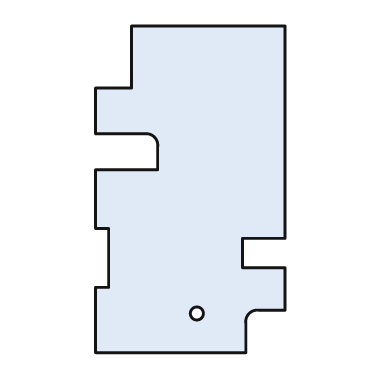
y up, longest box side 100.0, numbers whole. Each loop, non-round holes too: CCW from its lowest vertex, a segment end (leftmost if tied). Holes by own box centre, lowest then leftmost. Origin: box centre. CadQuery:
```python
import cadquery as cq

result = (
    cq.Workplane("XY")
    .moveTo(-29.0, -50.0)
    .lineTo(17.0, -50.0)
    .lineTo(17.0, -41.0)
    .threePointArc((18.0, -38.0), (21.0, -37.0))
    .lineTo(29.0, -37.0)
    .lineTo(29.0, -24.0)
    .lineTo(16.0, -24.0)
    .lineTo(16.0, -15.0)
    .lineTo(29.0, -15.0)
    .lineTo(29.0, 50.0)
    .lineTo(-18.0, 50.0)
    .lineTo(-18.0, 31.0)
    .lineTo(-29.0, 31.0)
    .lineTo(-29.0, 17.0)
    .lineTo(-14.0, 17.0)
    .threePointArc((-11.0, 16.0), (-10.0, 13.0))
    .lineTo(-10.0, 6.0)
    .lineTo(-29.0, 6.0)
    .lineTo(-29.0, -12.0)
    .lineTo(-25.0, -12.0)
    .lineTo(-25.0, -30.0)
    .lineTo(-29.0, -30.0)
    .close()
    .moveTo(2.0, -38.0)
    .circle(2.0)
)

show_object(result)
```